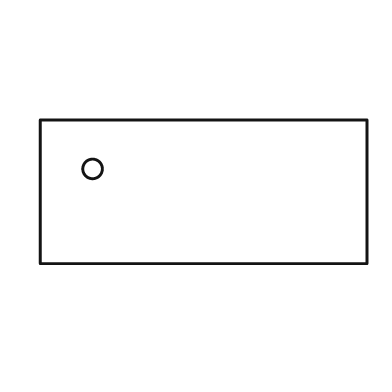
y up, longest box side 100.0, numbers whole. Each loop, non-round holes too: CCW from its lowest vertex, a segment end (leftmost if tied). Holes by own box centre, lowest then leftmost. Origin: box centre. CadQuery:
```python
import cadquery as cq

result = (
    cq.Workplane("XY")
    .moveTo(-50.0, -22.0)
    .lineTo(50.0, -22.0)
    .lineTo(50.0, 22.0)
    .lineTo(-50.0, 22.0)
    .close()
    .moveTo(-34.0, 7.0)
    .circle(3.0)
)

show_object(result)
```